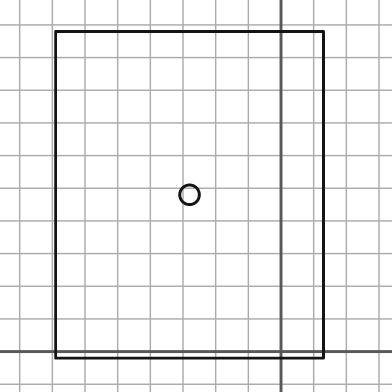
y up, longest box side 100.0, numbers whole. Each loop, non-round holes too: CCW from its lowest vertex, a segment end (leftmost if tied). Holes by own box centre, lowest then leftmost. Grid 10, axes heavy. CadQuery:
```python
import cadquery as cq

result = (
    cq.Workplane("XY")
    .moveTo(-69.0, -2.0)
    .lineTo(13.0, -2.0)
    .lineTo(13.0, 98.0)
    .lineTo(-69.0, 98.0)
    .close()
    .moveTo(-28.0, 48.0)
    .circle(3.0)
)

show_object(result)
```